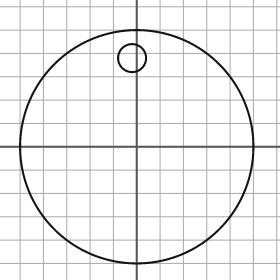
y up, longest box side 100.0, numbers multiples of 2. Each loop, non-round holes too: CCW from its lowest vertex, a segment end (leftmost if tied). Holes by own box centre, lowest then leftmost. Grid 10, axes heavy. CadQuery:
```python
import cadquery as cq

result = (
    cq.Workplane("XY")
    .moveTo(0.0, 0.0)
    .circle(50.0)
    .moveTo(-2.0, 38.0)
    .circle(6.0)
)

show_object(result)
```